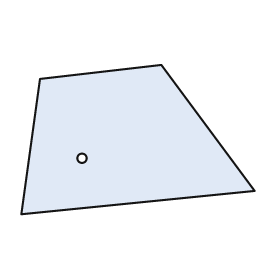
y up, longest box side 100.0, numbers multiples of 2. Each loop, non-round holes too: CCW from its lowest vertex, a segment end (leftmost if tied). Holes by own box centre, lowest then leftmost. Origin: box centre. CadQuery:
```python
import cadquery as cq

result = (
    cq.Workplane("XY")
    .moveTo(-50.0, -32.0)
    .lineTo(50.0, -22.0)
    .lineTo(10.0, 32.0)
    .lineTo(-42.0, 26.0)
    .close()
    .moveTo(-24.0, -8.0)
    .circle(2.0)
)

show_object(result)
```